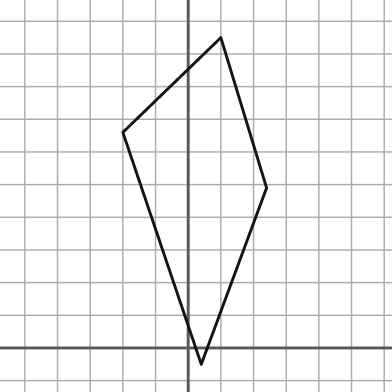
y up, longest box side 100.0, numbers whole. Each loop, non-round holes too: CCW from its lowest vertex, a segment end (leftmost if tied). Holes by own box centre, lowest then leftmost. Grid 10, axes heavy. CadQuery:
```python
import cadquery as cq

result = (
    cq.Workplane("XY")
    .moveTo(4.0, -5.0)
    .lineTo(24.0, 49.0)
    .lineTo(10.0, 95.0)
    .lineTo(-20.0, 66.0)
    .close()
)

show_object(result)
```